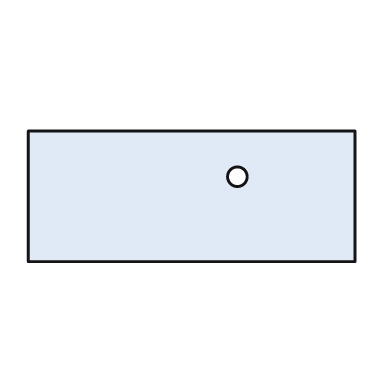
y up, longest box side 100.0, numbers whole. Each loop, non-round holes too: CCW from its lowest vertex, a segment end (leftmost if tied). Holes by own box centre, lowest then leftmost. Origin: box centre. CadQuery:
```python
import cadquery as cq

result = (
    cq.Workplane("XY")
    .moveTo(-50.0, -20.0)
    .lineTo(50.0, -20.0)
    .lineTo(50.0, 20.0)
    .lineTo(-50.0, 20.0)
    .close()
    .moveTo(14.0, 6.0)
    .circle(3.0)
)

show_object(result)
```